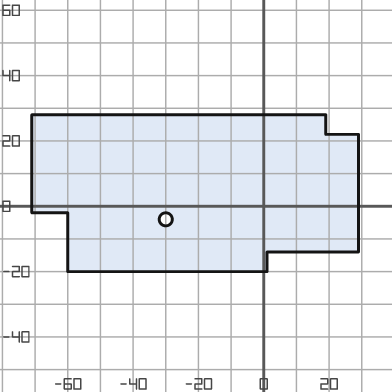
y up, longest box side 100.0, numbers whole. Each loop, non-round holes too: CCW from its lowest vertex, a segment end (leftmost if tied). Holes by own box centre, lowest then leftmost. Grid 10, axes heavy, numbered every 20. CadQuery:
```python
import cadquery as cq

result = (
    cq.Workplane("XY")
    .moveTo(-60.0, -20.0)
    .lineTo(1.0, -20.0)
    .lineTo(1.0, -14.0)
    .lineTo(29.0, -14.0)
    .lineTo(29.0, 22.0)
    .lineTo(19.0, 22.0)
    .lineTo(19.0, 28.0)
    .lineTo(-71.0, 28.0)
    .lineTo(-71.0, -2.0)
    .lineTo(-60.0, -2.0)
    .close()
    .moveTo(-30.0, -4.0)
    .circle(2.0)
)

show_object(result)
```